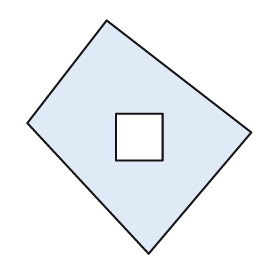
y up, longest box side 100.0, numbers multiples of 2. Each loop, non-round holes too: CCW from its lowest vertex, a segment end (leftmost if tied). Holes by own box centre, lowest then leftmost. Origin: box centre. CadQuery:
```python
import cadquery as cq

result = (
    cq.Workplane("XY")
    .moveTo(4.0, -50.0)
    .lineTo(48.0, 2.0)
    .lineTo(-14.0, 50.0)
    .lineTo(-48.0, 6.0)
    .close()
    .moveTo(-10.0, -10.0)
    .lineTo(10.0, -10.0)
    .lineTo(10.0, 10.0)
    .lineTo(-10.0, 10.0)
    .close()
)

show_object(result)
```